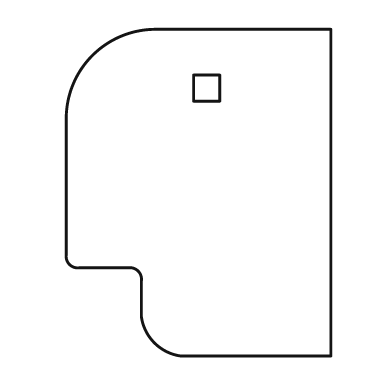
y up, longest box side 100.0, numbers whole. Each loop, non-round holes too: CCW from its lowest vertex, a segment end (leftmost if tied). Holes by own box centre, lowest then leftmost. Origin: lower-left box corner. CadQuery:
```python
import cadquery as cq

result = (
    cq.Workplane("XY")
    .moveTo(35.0, 0.0)
    .lineTo(81.0, 0.0)
    .lineTo(81.0, 100.0)
    .lineTo(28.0, 100.0)
    .threePointArc((8.0, 92.0), (0.0, 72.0))
    .lineTo(0.0, 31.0)
    .threePointArc((1.0, 28.0), (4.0, 27.0))
    .lineTo(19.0, 27.0)
    .threePointArc((22.0, 26.0), (23.0, 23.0))
    .lineTo(23.0, 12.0)
    .threePointArc((27.0, 4.0), (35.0, 0.0))
    .close()
    .moveTo(39.0, 78.0)
    .lineTo(47.0, 78.0)
    .lineTo(47.0, 86.0)
    .lineTo(39.0, 86.0)
    .close()
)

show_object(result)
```